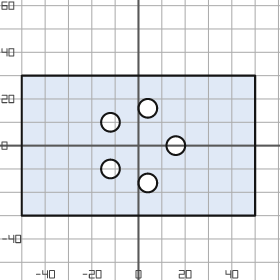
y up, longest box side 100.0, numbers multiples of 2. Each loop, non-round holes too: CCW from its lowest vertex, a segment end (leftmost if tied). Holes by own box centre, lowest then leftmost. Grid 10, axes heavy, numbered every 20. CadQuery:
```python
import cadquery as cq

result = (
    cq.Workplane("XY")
    .moveTo(-50.0, -30.0)
    .lineTo(50.0, -30.0)
    .lineTo(50.0, 30.0)
    .lineTo(-50.0, 30.0)
    .close()
    .moveTo(4.0, -16.0)
    .circle(4.0)
    .moveTo(-12.0, -10.0)
    .circle(4.0)
    .moveTo(16.0, 0.0)
    .circle(4.0)
    .moveTo(-12.0, 10.0)
    .circle(4.0)
    .moveTo(4.0, 16.0)
    .circle(4.0)
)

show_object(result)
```